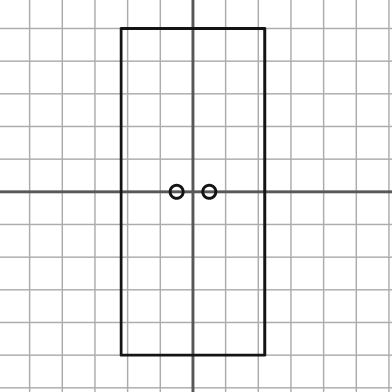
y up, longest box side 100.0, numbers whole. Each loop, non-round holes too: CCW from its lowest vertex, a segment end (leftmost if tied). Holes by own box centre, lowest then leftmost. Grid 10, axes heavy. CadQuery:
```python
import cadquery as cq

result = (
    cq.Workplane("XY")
    .moveTo(-22.0, -50.0)
    .lineTo(22.0, -50.0)
    .lineTo(22.0, 50.0)
    .lineTo(-22.0, 50.0)
    .close()
    .moveTo(-5.0, 0.0)
    .circle(2.0)
    .moveTo(5.0, 0.0)
    .circle(2.0)
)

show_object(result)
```